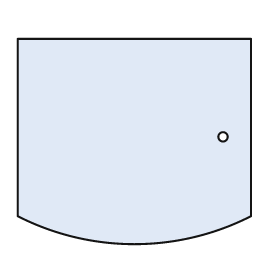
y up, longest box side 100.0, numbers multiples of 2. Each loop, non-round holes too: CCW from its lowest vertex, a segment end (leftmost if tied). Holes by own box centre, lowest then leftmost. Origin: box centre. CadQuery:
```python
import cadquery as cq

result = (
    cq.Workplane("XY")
    .moveTo(-50.0, -32.0)
    .threePointArc((0.0, -44.0), (50.0, -32.0))
    .lineTo(50.0, 44.0)
    .lineTo(-50.0, 44.0)
    .close()
    .moveTo(38.0, 2.0)
    .circle(2.0)
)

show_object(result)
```